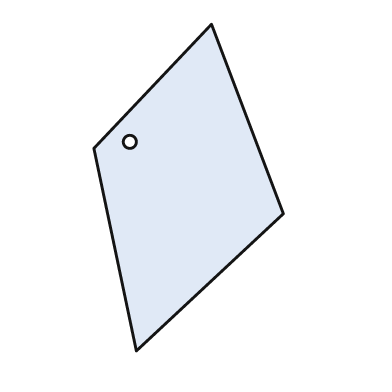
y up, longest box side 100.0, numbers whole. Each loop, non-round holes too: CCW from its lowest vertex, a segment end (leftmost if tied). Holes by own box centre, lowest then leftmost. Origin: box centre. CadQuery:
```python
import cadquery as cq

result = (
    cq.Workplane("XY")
    .moveTo(-16.0, -50.0)
    .lineTo(29.0, -8.0)
    .lineTo(7.0, 50.0)
    .lineTo(-29.0, 12.0)
    .close()
    .moveTo(-18.0, 14.0)
    .circle(2.0)
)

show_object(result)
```